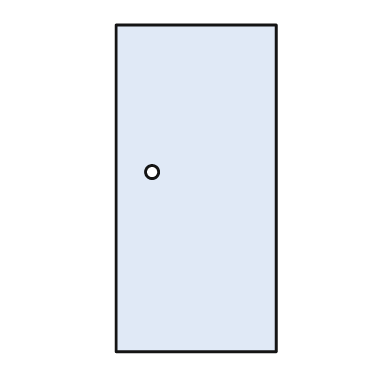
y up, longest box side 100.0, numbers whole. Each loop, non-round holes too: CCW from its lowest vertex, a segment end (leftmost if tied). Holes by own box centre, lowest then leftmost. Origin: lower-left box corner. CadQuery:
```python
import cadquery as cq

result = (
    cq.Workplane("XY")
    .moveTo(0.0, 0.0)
    .lineTo(49.0, 0.0)
    .lineTo(49.0, 100.0)
    .lineTo(0.0, 100.0)
    .close()
    .moveTo(11.0, 55.0)
    .circle(2.0)
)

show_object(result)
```